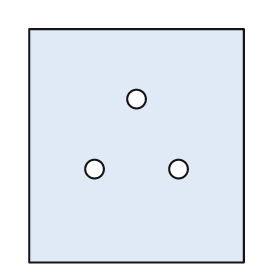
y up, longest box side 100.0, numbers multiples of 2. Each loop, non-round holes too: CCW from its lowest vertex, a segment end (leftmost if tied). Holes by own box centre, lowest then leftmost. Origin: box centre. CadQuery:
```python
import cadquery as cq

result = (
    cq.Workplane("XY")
    .moveTo(-46.0, -50.0)
    .lineTo(46.0, -50.0)
    .lineTo(46.0, 50.0)
    .lineTo(-46.0, 50.0)
    .close()
    .moveTo(-18.0, -10.0)
    .circle(4.0)
    .moveTo(18.0, -10.0)
    .circle(4.0)
    .moveTo(0.0, 20.0)
    .circle(4.0)
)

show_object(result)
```